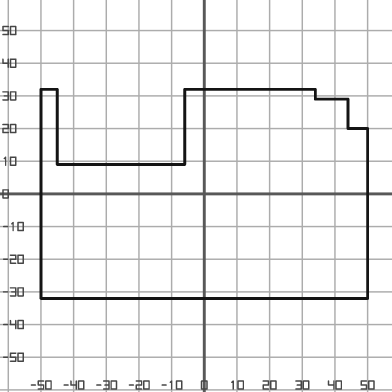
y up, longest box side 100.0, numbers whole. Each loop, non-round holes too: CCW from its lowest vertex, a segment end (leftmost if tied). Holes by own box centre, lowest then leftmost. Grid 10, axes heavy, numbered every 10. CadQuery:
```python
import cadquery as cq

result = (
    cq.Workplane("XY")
    .moveTo(-50.0, -32.0)
    .lineTo(50.0, -32.0)
    .lineTo(50.0, 20.0)
    .lineTo(44.0, 20.0)
    .lineTo(44.0, 29.0)
    .lineTo(34.0, 29.0)
    .lineTo(34.0, 32.0)
    .lineTo(-6.0, 32.0)
    .lineTo(-6.0, 9.0)
    .lineTo(-45.0, 9.0)
    .lineTo(-45.0, 32.0)
    .lineTo(-50.0, 32.0)
    .close()
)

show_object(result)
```